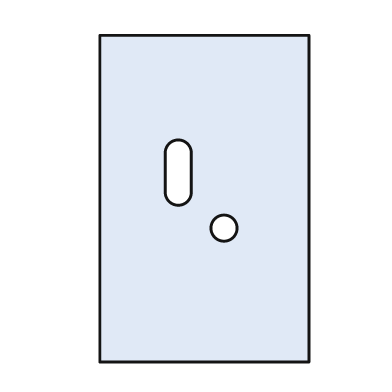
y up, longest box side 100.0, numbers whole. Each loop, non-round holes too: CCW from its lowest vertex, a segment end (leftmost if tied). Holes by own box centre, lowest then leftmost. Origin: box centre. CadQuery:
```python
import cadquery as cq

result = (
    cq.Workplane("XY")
    .moveTo(-32.0, -50.0)
    .lineTo(32.0, -50.0)
    .lineTo(32.0, 50.0)
    .lineTo(-32.0, 50.0)
    .close()
    .moveTo(6.0, -9.0)
    .circle(4.0)
    .moveTo(-12.0, 2.0)
    .threePointArc((-8.0, -2.0), (-4.0, 2.0))
    .lineTo(-4.0, 14.0)
    .threePointArc((-8.0, 18.0), (-12.0, 14.0))
    .close()
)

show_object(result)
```